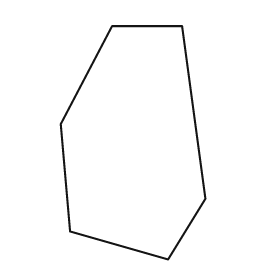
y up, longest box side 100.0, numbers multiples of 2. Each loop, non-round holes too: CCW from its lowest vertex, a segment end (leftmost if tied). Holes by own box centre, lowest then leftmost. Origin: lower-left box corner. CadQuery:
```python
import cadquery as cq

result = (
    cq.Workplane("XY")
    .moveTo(46.0, 0.0)
    .lineTo(62.0, 26.0)
    .lineTo(52.0, 100.0)
    .lineTo(22.0, 100.0)
    .lineTo(0.0, 58.0)
    .lineTo(4.0, 12.0)
    .close()
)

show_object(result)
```